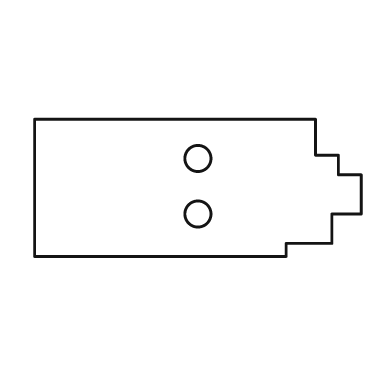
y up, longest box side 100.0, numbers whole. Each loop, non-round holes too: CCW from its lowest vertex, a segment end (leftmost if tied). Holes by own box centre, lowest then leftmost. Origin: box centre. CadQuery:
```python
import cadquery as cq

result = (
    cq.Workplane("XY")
    .moveTo(-50.0, -21.0)
    .lineTo(27.0, -21.0)
    .lineTo(27.0, -17.0)
    .lineTo(41.0, -17.0)
    .lineTo(41.0, -8.0)
    .lineTo(50.0, -8.0)
    .lineTo(50.0, 4.0)
    .lineTo(43.0, 4.0)
    .lineTo(43.0, 10.0)
    .lineTo(36.0, 10.0)
    .lineTo(36.0, 21.0)
    .lineTo(-50.0, 21.0)
    .close()
    .moveTo(0.0, -8.0)
    .circle(4.0)
    .moveTo(0.0, 9.0)
    .circle(4.0)
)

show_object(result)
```